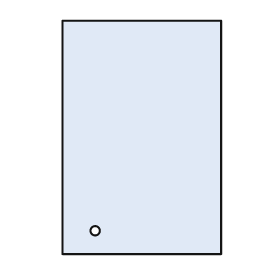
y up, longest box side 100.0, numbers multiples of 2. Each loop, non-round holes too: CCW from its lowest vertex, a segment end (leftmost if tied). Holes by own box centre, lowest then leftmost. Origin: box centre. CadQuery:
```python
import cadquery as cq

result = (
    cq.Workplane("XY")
    .moveTo(-34.0, -50.0)
    .lineTo(34.0, -50.0)
    .lineTo(34.0, 50.0)
    .lineTo(-34.0, 50.0)
    .close()
    .moveTo(-20.0, -40.0)
    .circle(2.0)
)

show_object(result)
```